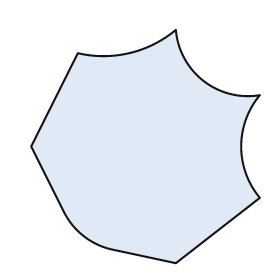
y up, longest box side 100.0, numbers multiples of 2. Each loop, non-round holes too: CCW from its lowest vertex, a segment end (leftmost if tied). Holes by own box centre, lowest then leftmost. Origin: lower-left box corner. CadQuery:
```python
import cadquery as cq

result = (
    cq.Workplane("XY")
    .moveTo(62.0, 0.0)
    .lineTo(98.0, 28.0)
    .threePointArc((90.0, 50.0), (98.0, 72.0))
    .threePointArc((74.0, 78.0), (62.0, 100.0))
    .threePointArc((42.0, 90.0), (20.0, 90.0))
    .lineTo(0.0, 50.0)
    .lineTo(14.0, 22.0)
    .threePointArc((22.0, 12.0), (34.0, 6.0))
    .close()
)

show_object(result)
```